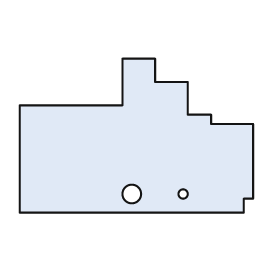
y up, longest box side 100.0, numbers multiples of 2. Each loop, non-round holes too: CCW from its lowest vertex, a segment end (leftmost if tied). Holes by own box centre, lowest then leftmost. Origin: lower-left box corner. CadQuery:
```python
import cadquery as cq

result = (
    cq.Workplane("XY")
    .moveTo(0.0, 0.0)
    .lineTo(96.0, 0.0)
    .lineTo(96.0, 6.0)
    .lineTo(100.0, 6.0)
    .lineTo(100.0, 38.0)
    .lineTo(82.0, 38.0)
    .lineTo(82.0, 42.0)
    .lineTo(72.0, 42.0)
    .lineTo(72.0, 56.0)
    .lineTo(58.0, 56.0)
    .lineTo(58.0, 66.0)
    .lineTo(44.0, 66.0)
    .lineTo(44.0, 46.0)
    .lineTo(0.0, 46.0)
    .close()
    .moveTo(48.0, 8.0)
    .circle(4.0)
    .moveTo(70.0, 8.0)
    .circle(2.0)
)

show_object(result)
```